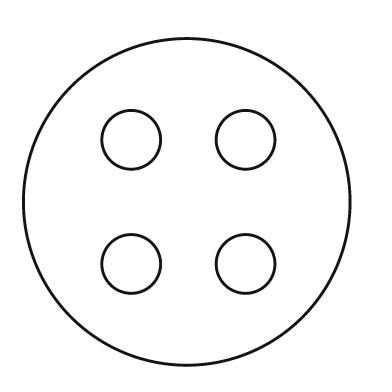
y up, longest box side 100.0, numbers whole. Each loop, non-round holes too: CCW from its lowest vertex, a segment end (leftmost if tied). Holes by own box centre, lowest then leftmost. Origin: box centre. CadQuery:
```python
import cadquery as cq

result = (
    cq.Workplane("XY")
    .moveTo(0.0, 0.0)
    .circle(50.0)
    .moveTo(-17.0, -19.0)
    .circle(9.0)
    .moveTo(18.0, -19.0)
    .circle(9.0)
    .moveTo(-17.0, 19.0)
    .circle(9.0)
    .moveTo(18.0, 19.0)
    .circle(9.0)
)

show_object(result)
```